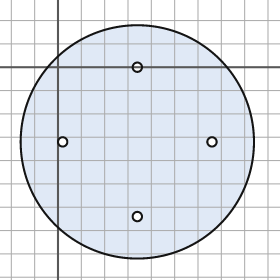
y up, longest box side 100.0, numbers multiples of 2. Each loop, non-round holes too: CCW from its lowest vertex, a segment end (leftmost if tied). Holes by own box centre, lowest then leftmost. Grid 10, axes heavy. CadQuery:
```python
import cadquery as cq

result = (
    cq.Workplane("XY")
    .moveTo(34.0, -32.0)
    .circle(50.0)
    .moveTo(34.0, -64.0)
    .circle(2.0)
    .moveTo(2.0, -32.0)
    .circle(2.0)
    .moveTo(66.0, -32.0)
    .circle(2.0)
    .moveTo(34.0, 0.0)
    .circle(2.0)
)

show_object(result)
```